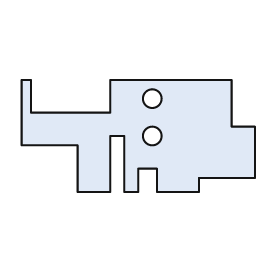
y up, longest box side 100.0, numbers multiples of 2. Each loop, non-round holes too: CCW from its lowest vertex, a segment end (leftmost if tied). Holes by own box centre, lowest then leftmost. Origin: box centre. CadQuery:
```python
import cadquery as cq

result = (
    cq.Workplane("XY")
    .moveTo(-26.0, -24.0)
    .lineTo(-12.0, -24.0)
    .lineTo(-12.0, 0.0)
    .lineTo(-6.0, 0.0)
    .lineTo(-6.0, -24.0)
    .lineTo(0.0, -24.0)
    .lineTo(0.0, -14.0)
    .lineTo(8.0, -14.0)
    .lineTo(8.0, -24.0)
    .lineTo(26.0, -24.0)
    .lineTo(26.0, -18.0)
    .lineTo(50.0, -18.0)
    .lineTo(50.0, 4.0)
    .lineTo(40.0, 4.0)
    .lineTo(40.0, 24.0)
    .lineTo(-12.0, 24.0)
    .lineTo(-12.0, 10.0)
    .lineTo(-46.0, 10.0)
    .lineTo(-46.0, 24.0)
    .lineTo(-50.0, 24.0)
    .lineTo(-50.0, -4.0)
    .lineTo(-26.0, -4.0)
    .close()
    .moveTo(6.0, 0.0)
    .circle(4.0)
    .moveTo(6.0, 16.0)
    .circle(4.0)
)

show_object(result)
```